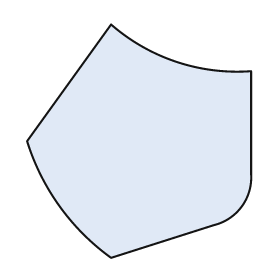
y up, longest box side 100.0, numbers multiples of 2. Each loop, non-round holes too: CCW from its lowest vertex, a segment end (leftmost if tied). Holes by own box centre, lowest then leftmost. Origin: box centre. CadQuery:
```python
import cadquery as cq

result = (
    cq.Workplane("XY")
    .moveTo(-12.0, -50.0)
    .lineTo(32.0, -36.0)
    .threePointArc((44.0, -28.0), (48.0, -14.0))
    .lineTo(48.0, 30.0)
    .threePointArc((16.0, 34.0), (-12.0, 50.0))
    .lineTo(-48.0, 0.0)
    .threePointArc((-34.0, -28.0), (-12.0, -50.0))
    .close()
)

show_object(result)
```